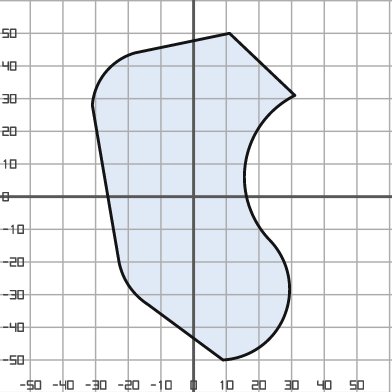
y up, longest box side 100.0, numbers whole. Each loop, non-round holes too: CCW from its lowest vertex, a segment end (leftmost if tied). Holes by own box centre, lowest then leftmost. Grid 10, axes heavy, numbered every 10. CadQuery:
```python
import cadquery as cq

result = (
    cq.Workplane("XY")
    .moveTo(9.0, -50.0)
    .threePointArc((28.0, -36.0), (23.0, -13.0))
    .threePointArc((16.0, 11.0), (31.0, 31.0))
    .lineTo(11.0, 50.0)
    .lineTo(-18.0, 44.0)
    .threePointArc((-27.0, 38.0), (-31.0, 28.0))
    .lineTo(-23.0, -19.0)
    .threePointArc((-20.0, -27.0), (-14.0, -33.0))
    .close()
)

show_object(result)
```